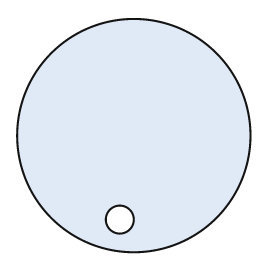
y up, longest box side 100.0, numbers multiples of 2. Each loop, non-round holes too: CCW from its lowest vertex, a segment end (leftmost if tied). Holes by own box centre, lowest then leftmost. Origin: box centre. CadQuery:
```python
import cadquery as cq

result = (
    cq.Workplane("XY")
    .moveTo(0.0, 0.0)
    .circle(50.0)
    .moveTo(-6.0, -36.0)
    .circle(6.0)
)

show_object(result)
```